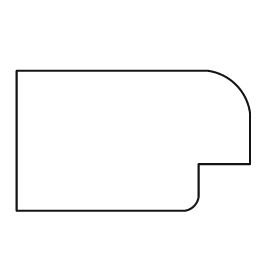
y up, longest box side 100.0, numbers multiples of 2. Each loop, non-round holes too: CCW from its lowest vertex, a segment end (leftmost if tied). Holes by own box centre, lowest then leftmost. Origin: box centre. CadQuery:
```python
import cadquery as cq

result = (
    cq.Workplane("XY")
    .moveTo(-50.0, -30.0)
    .lineTo(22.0, -30.0)
    .threePointArc((26.0, -28.0), (28.0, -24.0))
    .lineTo(28.0, -10.0)
    .lineTo(50.0, -10.0)
    .lineTo(50.0, 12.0)
    .threePointArc((44.0, 24.0), (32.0, 30.0))
    .lineTo(-50.0, 30.0)
    .close()
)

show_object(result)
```